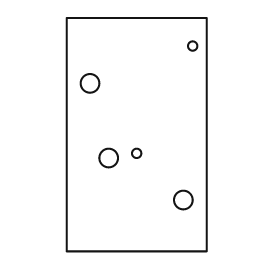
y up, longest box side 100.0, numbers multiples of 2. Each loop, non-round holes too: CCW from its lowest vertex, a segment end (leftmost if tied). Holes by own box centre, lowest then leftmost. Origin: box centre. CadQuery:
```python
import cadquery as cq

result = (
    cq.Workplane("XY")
    .moveTo(-30.0, -50.0)
    .lineTo(30.0, -50.0)
    .lineTo(30.0, 50.0)
    .lineTo(-30.0, 50.0)
    .close()
    .moveTo(20.0, -28.0)
    .circle(4.0)
    .moveTo(-12.0, -10.0)
    .circle(4.0)
    .moveTo(0.0, -8.0)
    .circle(2.0)
    .moveTo(-20.0, 22.0)
    .circle(4.0)
    .moveTo(24.0, 38.0)
    .circle(2.0)
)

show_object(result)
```